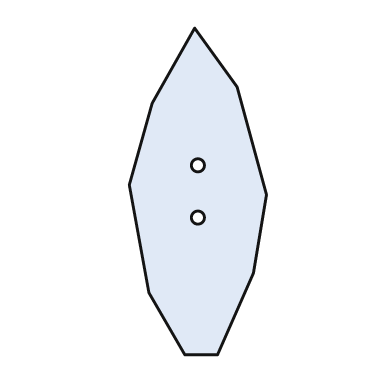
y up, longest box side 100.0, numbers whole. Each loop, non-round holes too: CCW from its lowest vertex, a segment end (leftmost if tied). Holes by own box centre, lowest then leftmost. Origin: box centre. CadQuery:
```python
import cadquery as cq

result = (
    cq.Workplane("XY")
    .moveTo(-4.0, -50.0)
    .lineTo(6.0, -50.0)
    .lineTo(17.0, -25.0)
    .lineTo(21.0, -1.0)
    .lineTo(12.0, 32.0)
    .lineTo(-1.0, 50.0)
    .lineTo(-14.0, 27.0)
    .lineTo(-21.0, 2.0)
    .lineTo(-15.0, -31.0)
    .close()
    .moveTo(0.0, -8.0)
    .circle(2.0)
    .moveTo(0.0, 8.0)
    .circle(2.0)
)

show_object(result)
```